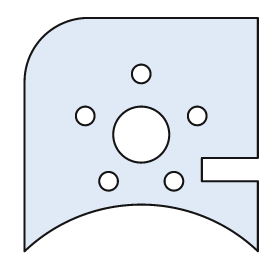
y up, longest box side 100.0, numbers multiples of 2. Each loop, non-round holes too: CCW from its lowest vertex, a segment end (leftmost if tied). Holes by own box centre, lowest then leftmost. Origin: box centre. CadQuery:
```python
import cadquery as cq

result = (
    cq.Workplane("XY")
    .moveTo(-50.0, -50.0)
    .threePointArc((0.0, -30.0), (50.0, -50.0))
    .lineTo(50.0, -20.0)
    .lineTo(26.0, -20.0)
    .lineTo(26.0, -10.0)
    .lineTo(50.0, -10.0)
    .lineTo(50.0, 50.0)
    .lineTo(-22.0, 50.0)
    .threePointArc((-42.0, 42.0), (-50.0, 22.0))
    .close()
    .moveTo(-14.0, -20.0)
    .circle(4.0)
    .moveTo(14.0, -20.0)
    .circle(4.0)
    .moveTo(0.0, 0.0)
    .circle(12.0)
    .moveTo(-24.0, 8.0)
    .circle(4.0)
    .moveTo(24.0, 8.0)
    .circle(4.0)
    .moveTo(0.0, 26.0)
    .circle(4.0)
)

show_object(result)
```